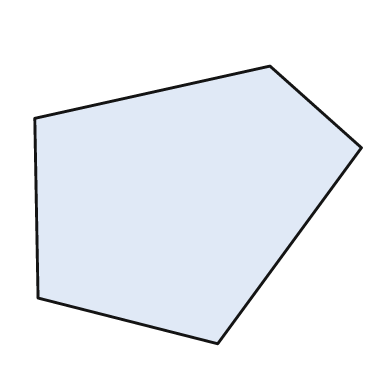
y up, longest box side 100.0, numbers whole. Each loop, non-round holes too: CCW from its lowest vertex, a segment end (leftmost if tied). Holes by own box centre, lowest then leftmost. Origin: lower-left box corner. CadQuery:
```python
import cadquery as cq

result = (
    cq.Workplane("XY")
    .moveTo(56.0, 0.0)
    .lineTo(100.0, 60.0)
    .lineTo(72.0, 85.0)
    .lineTo(0.0, 69.0)
    .lineTo(1.0, 14.0)
    .close()
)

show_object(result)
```